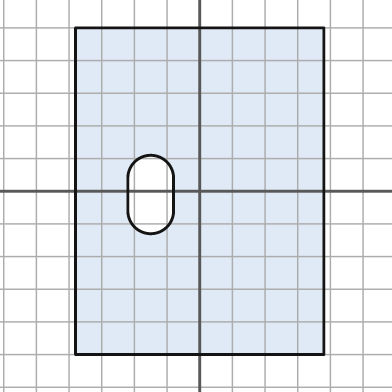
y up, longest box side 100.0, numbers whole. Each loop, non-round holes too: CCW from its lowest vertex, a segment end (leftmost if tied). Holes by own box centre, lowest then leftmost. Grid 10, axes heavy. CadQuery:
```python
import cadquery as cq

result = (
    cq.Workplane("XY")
    .moveTo(-38.0, -50.0)
    .lineTo(38.0, -50.0)
    .lineTo(38.0, 50.0)
    .lineTo(-38.0, 50.0)
    .close()
    .moveTo(-22.0, -6.0)
    .threePointArc((-15.0, -13.0), (-8.0, -6.0))
    .lineTo(-8.0, 4.0)
    .threePointArc((-15.0, 11.0), (-22.0, 4.0))
    .close()
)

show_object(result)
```